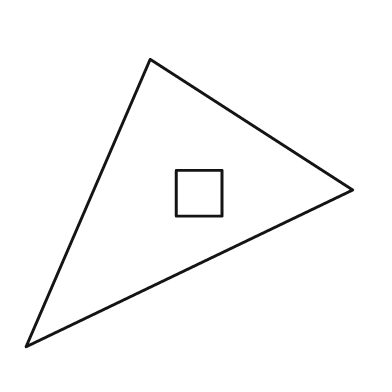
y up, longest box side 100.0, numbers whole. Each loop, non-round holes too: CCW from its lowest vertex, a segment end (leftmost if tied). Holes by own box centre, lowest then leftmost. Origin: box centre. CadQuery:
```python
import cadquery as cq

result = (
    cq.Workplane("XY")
    .moveTo(-50.0, -44.0)
    .lineTo(50.0, 4.0)
    .lineTo(-12.0, 44.0)
    .close()
    .moveTo(-4.0, -4.0)
    .lineTo(10.0, -4.0)
    .lineTo(10.0, 10.0)
    .lineTo(-4.0, 10.0)
    .close()
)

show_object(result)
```